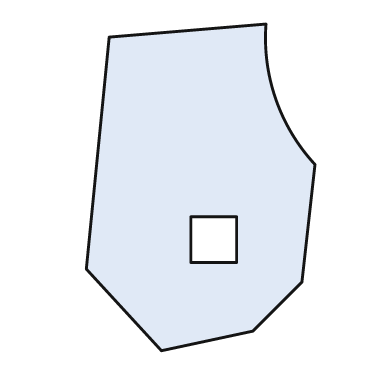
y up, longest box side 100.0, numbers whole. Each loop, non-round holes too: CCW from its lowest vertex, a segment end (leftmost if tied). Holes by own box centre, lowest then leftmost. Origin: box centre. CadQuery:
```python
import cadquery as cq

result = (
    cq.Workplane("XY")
    .moveTo(-12.0, -50.0)
    .lineTo(16.0, -44.0)
    .lineTo(31.0, -29.0)
    .lineTo(35.0, 7.0)
    .threePointArc((23.0, 27.0), (20.0, 50.0))
    .lineTo(-28.0, 46.0)
    .lineTo(-35.0, -25.0)
    .close()
    .moveTo(-3.0, -23.0)
    .lineTo(11.0, -23.0)
    .lineTo(11.0, -9.0)
    .lineTo(-3.0, -9.0)
    .close()
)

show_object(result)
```